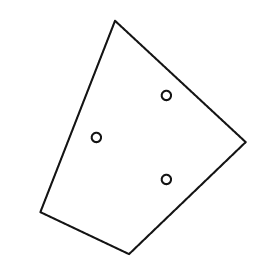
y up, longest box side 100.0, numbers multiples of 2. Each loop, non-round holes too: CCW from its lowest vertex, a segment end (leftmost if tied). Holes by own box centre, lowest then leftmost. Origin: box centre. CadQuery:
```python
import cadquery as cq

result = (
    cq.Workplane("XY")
    .moveTo(-6.0, -50.0)
    .lineTo(44.0, -2.0)
    .lineTo(-12.0, 50.0)
    .lineTo(-44.0, -32.0)
    .close()
    .moveTo(10.0, -18.0)
    .circle(2.0)
    .moveTo(-20.0, 0.0)
    .circle(2.0)
    .moveTo(10.0, 18.0)
    .circle(2.0)
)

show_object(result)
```